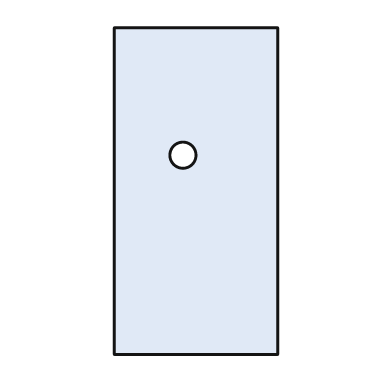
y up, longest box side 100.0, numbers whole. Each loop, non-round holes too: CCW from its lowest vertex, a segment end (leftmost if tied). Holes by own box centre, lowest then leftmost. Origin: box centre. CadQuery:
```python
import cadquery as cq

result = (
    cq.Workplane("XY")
    .moveTo(-25.0, -50.0)
    .lineTo(25.0, -50.0)
    .lineTo(25.0, 50.0)
    .lineTo(-25.0, 50.0)
    .close()
    .moveTo(-4.0, 11.0)
    .circle(4.0)
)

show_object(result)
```